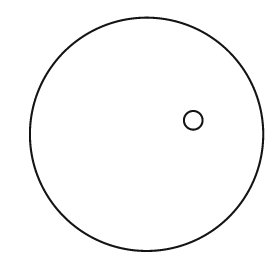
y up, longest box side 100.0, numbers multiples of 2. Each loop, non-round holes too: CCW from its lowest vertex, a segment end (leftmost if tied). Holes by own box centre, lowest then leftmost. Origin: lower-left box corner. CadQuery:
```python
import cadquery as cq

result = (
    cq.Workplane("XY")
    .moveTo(50.0, 50.0)
    .circle(50.0)
    .moveTo(70.0, 56.0)
    .circle(4.0)
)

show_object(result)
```